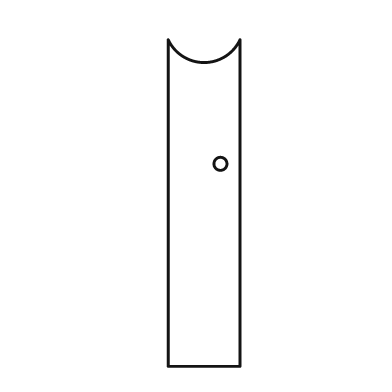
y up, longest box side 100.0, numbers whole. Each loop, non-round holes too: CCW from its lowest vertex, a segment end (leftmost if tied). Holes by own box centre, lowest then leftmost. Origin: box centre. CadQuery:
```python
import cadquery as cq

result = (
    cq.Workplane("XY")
    .moveTo(-11.0, -50.0)
    .lineTo(11.0, -50.0)
    .lineTo(11.0, 50.0)
    .threePointArc((0.0, 43.0), (-11.0, 50.0))
    .close()
    .moveTo(5.0, 12.0)
    .circle(2.0)
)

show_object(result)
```